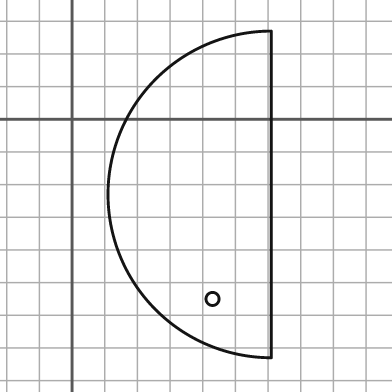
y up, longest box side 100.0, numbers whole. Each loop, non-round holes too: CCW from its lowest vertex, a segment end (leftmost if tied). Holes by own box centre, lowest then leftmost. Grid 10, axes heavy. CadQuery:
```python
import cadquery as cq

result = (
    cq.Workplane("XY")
    .moveTo(61.0, -73.0)
    .lineTo(61.0, 27.0)
    .threePointArc((11.0, -23.0), (61.0, -73.0))
    .close()
    .moveTo(43.0, -55.0)
    .circle(2.0)
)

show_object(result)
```